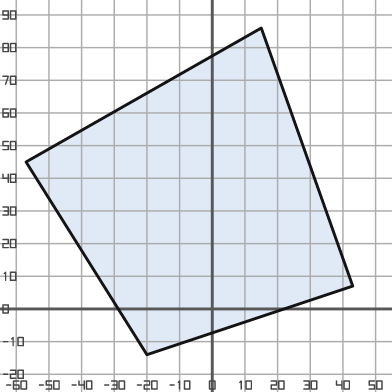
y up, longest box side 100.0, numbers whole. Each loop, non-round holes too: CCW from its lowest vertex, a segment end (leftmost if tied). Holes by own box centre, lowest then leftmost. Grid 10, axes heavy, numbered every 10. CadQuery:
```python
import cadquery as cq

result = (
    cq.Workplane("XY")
    .moveTo(-20.0, -14.0)
    .lineTo(43.0, 7.0)
    .lineTo(15.0, 86.0)
    .lineTo(-57.0, 45.0)
    .close()
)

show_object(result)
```